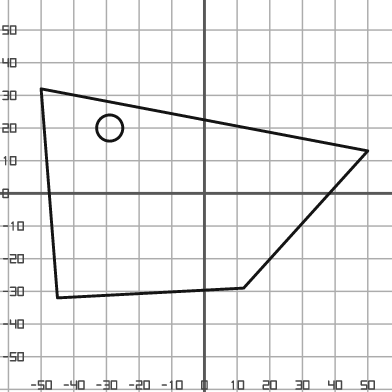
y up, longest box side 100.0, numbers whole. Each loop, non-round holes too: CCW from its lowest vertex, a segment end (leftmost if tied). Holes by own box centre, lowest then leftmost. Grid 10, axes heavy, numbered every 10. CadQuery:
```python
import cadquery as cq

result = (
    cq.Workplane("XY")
    .moveTo(-45.0, -32.0)
    .lineTo(12.0, -29.0)
    .lineTo(50.0, 13.0)
    .lineTo(-50.0, 32.0)
    .close()
    .moveTo(-29.0, 20.0)
    .circle(4.0)
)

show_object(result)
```